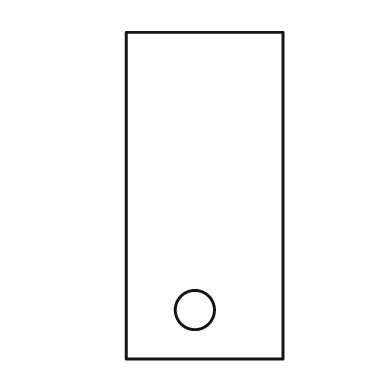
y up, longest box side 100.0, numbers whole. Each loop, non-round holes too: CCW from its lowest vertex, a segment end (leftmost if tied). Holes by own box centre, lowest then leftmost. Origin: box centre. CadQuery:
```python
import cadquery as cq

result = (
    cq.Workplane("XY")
    .moveTo(-24.0, -50.0)
    .lineTo(24.0, -50.0)
    .lineTo(24.0, 50.0)
    .lineTo(-24.0, 50.0)
    .close()
    .moveTo(-3.0, -35.0)
    .circle(6.0)
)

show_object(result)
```